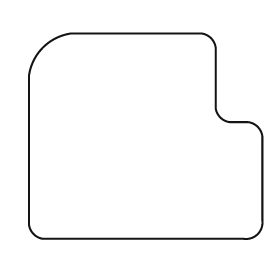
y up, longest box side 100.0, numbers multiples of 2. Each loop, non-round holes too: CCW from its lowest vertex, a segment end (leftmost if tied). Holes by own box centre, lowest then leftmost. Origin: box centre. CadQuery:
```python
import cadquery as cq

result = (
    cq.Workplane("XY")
    .moveTo(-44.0, -44.0)
    .lineTo(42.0, -44.0)
    .threePointArc((48.0, -42.0), (50.0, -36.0))
    .lineTo(50.0, 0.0)
    .threePointArc((48.0, 4.0), (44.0, 6.0))
    .lineTo(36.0, 6.0)
    .threePointArc((32.0, 8.0), (30.0, 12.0))
    .lineTo(30.0, 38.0)
    .threePointArc((28.0, 42.0), (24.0, 44.0))
    .lineTo(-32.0, 44.0)
    .threePointArc((-44.0, 38.0), (-50.0, 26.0))
    .lineTo(-50.0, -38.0)
    .threePointArc((-48.0, -42.0), (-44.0, -44.0))
    .close()
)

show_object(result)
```